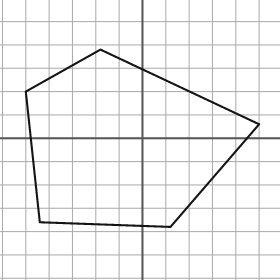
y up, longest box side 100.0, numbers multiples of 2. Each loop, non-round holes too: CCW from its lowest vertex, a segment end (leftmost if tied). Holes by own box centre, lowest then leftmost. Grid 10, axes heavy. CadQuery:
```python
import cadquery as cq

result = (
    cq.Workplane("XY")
    .moveTo(12.0, -38.0)
    .lineTo(50.0, 6.0)
    .lineTo(-18.0, 38.0)
    .lineTo(-50.0, 20.0)
    .lineTo(-44.0, -36.0)
    .close()
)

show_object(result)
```